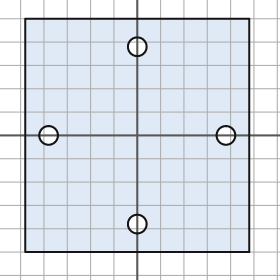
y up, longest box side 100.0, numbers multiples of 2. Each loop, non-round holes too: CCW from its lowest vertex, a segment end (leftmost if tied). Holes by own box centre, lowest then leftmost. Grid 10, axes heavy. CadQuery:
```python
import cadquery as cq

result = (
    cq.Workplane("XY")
    .moveTo(-48.0, -50.0)
    .lineTo(48.0, -50.0)
    .lineTo(48.0, 50.0)
    .lineTo(-48.0, 50.0)
    .close()
    .moveTo(0.0, -38.0)
    .circle(4.0)
    .moveTo(-38.0, 0.0)
    .circle(4.0)
    .moveTo(38.0, 0.0)
    .circle(4.0)
    .moveTo(0.0, 38.0)
    .circle(4.0)
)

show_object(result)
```